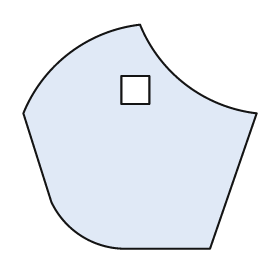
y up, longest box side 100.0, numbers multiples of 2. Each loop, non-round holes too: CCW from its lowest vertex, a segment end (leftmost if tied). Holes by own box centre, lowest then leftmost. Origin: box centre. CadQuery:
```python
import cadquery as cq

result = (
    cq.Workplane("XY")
    .moveTo(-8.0, -48.0)
    .lineTo(30.0, -48.0)
    .lineTo(50.0, 10.0)
    .threePointArc((20.0, 22.0), (0.0, 48.0))
    .threePointArc((-30.0, 36.0), (-50.0, 10.0))
    .lineTo(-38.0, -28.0)
    .threePointArc((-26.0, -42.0), (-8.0, -48.0))
    .close()
    .moveTo(-8.0, 14.0)
    .lineTo(4.0, 14.0)
    .lineTo(4.0, 26.0)
    .lineTo(-8.0, 26.0)
    .close()
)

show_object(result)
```